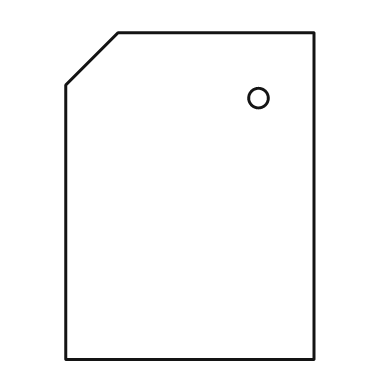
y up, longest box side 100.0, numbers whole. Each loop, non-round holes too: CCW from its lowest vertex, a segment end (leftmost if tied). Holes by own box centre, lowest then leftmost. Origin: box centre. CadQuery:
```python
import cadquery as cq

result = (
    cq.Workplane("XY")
    .moveTo(-38.0, -50.0)
    .lineTo(38.0, -50.0)
    .lineTo(38.0, 50.0)
    .lineTo(-22.0, 50.0)
    .lineTo(-38.0, 34.0)
    .close()
    .moveTo(21.0, 30.0)
    .circle(3.0)
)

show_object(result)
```